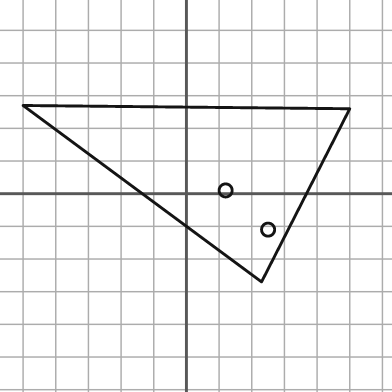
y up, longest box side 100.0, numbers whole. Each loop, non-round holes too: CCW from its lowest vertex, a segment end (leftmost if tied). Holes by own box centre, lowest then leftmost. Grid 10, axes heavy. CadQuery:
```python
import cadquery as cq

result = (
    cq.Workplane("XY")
    .moveTo(23.0, -27.0)
    .lineTo(50.0, 26.0)
    .lineTo(-50.0, 27.0)
    .close()
    .moveTo(25.0, -11.0)
    .circle(2.0)
    .moveTo(12.0, 1.0)
    .circle(2.0)
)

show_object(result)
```